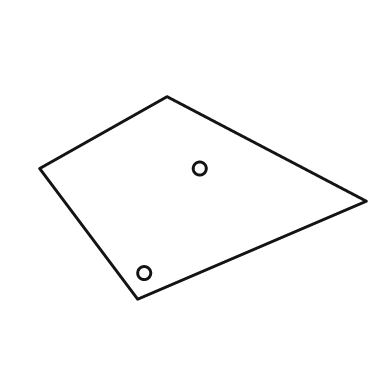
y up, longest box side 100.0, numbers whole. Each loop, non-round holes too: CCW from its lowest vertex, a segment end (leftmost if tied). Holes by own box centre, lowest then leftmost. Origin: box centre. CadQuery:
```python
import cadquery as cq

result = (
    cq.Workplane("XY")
    .moveTo(-20.0, -31.0)
    .lineTo(50.0, -1.0)
    .lineTo(-11.0, 31.0)
    .lineTo(-50.0, 9.0)
    .close()
    .moveTo(-18.0, -23.0)
    .circle(2.0)
    .moveTo(-1.0, 9.0)
    .circle(2.0)
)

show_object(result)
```